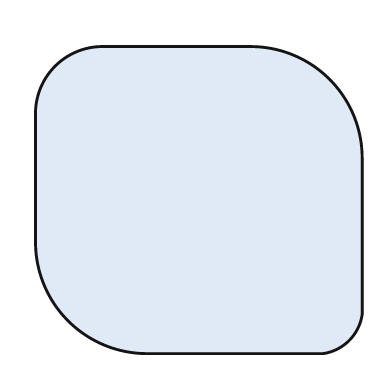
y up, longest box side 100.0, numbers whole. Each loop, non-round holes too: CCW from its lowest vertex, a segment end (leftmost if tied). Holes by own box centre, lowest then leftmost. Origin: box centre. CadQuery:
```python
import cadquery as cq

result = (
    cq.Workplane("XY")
    .moveTo(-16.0, -47.0)
    .lineTo(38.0, -47.0)
    .threePointArc((46.0, -43.0), (50.0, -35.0))
    .lineTo(50.0, 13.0)
    .threePointArc((40.0, 37.0), (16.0, 47.0))
    .lineTo(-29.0, 47.0)
    .threePointArc((-44.0, 41.0), (-50.0, 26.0))
    .lineTo(-50.0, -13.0)
    .threePointArc((-40.0, -37.0), (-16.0, -47.0))
    .close()
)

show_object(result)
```